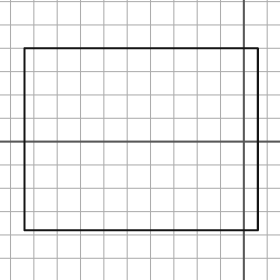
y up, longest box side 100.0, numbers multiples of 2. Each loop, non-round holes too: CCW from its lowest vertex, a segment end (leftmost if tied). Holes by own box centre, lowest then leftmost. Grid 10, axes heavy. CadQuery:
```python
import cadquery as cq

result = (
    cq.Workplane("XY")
    .moveTo(-94.0, -38.0)
    .lineTo(6.0, -38.0)
    .lineTo(6.0, 40.0)
    .lineTo(-94.0, 40.0)
    .close()
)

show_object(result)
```